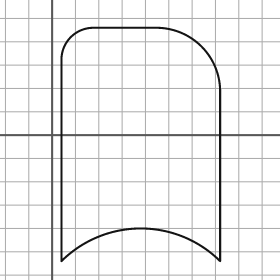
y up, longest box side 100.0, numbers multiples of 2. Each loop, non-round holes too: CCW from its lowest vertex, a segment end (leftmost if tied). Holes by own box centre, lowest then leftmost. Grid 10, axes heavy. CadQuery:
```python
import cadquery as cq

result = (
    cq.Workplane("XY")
    .moveTo(4.0, -54.0)
    .threePointArc((38.0, -40.0), (72.0, -54.0))
    .lineTo(72.0, 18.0)
    .threePointArc((64.0, 38.0), (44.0, 46.0))
    .lineTo(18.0, 46.0)
    .threePointArc((8.0, 42.0), (4.0, 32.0))
    .close()
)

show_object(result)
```